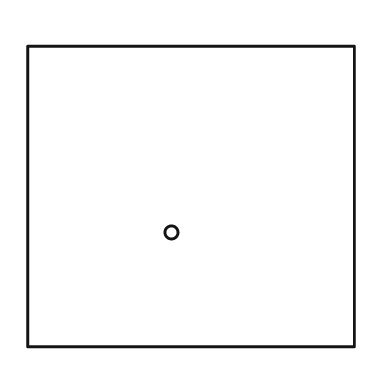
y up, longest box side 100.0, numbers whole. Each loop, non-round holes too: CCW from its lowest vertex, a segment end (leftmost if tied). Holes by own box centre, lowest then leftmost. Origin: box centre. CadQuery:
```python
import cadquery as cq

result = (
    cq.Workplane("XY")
    .moveTo(-50.0, -46.0)
    .lineTo(50.0, -46.0)
    .lineTo(50.0, 46.0)
    .lineTo(-50.0, 46.0)
    .close()
    .moveTo(-6.0, -11.0)
    .circle(2.0)
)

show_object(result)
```